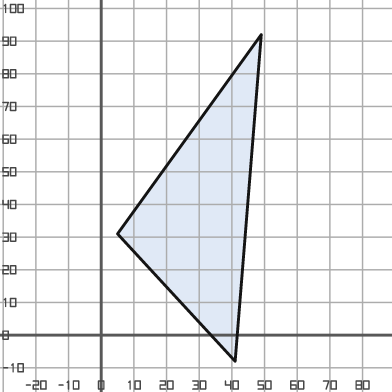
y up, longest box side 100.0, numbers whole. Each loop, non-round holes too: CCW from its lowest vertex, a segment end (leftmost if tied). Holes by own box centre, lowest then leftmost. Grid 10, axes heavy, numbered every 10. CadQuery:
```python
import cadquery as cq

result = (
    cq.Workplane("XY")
    .moveTo(41.0, -8.0)
    .lineTo(49.0, 92.0)
    .lineTo(5.0, 31.0)
    .close()
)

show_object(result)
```